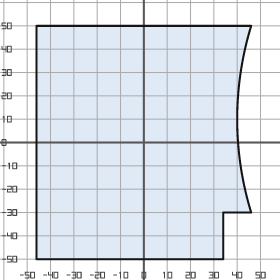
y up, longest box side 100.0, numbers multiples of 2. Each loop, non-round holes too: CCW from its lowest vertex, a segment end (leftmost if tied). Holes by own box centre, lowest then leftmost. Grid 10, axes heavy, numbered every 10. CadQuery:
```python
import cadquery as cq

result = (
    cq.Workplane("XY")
    .moveTo(-46.0, -50.0)
    .lineTo(34.0, -50.0)
    .lineTo(34.0, -30.0)
    .lineTo(46.0, -30.0)
    .threePointArc((40.0, 10.0), (46.0, 50.0))
    .lineTo(-46.0, 50.0)
    .close()
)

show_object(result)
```